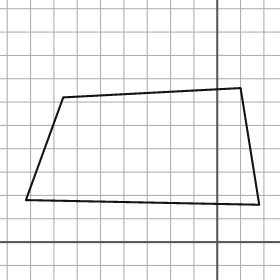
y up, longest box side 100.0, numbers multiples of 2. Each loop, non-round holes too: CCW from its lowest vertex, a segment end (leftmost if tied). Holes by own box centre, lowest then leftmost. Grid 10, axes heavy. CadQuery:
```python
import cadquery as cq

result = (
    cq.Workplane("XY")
    .moveTo(18.0, 16.0)
    .lineTo(10.0, 66.0)
    .lineTo(-66.0, 62.0)
    .lineTo(-82.0, 18.0)
    .close()
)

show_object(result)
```